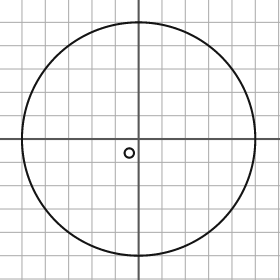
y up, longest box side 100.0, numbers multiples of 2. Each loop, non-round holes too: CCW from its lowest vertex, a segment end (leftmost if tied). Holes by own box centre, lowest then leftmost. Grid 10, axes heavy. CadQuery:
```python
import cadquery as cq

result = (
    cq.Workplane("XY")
    .moveTo(0.0, 0.0)
    .circle(50.0)
    .moveTo(-4.0, -6.0)
    .circle(2.0)
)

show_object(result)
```